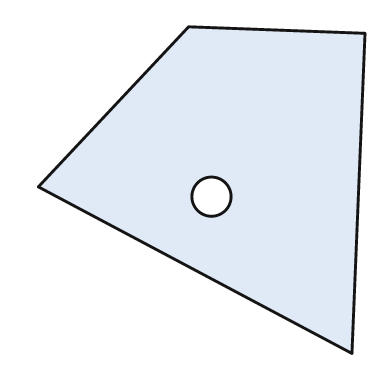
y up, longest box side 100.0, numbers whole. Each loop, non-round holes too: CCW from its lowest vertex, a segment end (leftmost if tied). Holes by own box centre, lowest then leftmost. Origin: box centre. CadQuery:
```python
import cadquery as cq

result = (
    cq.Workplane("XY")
    .moveTo(46.0, -50.0)
    .lineTo(50.0, 48.0)
    .lineTo(-4.0, 50.0)
    .lineTo(-50.0, 1.0)
    .close()
    .moveTo(3.0, -2.0)
    .circle(6.0)
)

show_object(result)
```